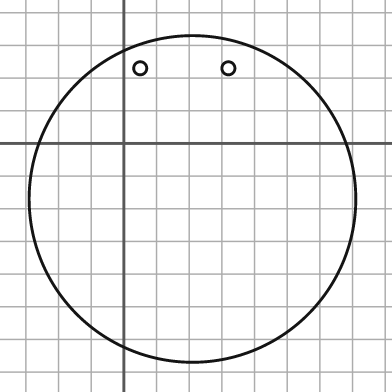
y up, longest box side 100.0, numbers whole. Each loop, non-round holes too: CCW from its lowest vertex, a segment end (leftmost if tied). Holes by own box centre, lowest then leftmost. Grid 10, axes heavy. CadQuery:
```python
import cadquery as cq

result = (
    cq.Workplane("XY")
    .moveTo(21.0, -17.0)
    .circle(50.0)
    .moveTo(5.0, 23.0)
    .circle(2.0)
    .moveTo(32.0, 23.0)
    .circle(2.0)
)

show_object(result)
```